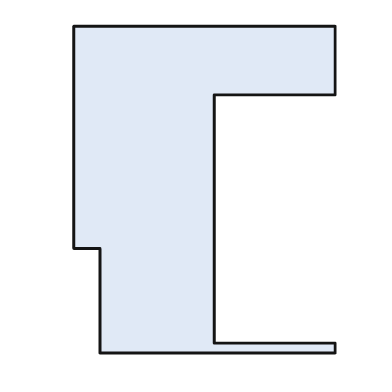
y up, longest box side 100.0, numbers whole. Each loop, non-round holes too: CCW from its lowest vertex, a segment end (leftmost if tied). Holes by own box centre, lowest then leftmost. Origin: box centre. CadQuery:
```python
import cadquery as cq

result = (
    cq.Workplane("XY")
    .moveTo(-32.0, -50.0)
    .lineTo(40.0, -50.0)
    .lineTo(40.0, -47.0)
    .lineTo(3.0, -47.0)
    .lineTo(3.0, 29.0)
    .lineTo(40.0, 29.0)
    .lineTo(40.0, 50.0)
    .lineTo(-40.0, 50.0)
    .lineTo(-40.0, -18.0)
    .lineTo(-32.0, -18.0)
    .close()
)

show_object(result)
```